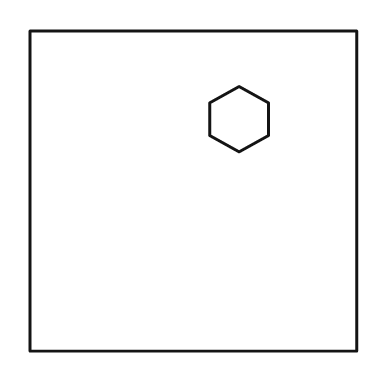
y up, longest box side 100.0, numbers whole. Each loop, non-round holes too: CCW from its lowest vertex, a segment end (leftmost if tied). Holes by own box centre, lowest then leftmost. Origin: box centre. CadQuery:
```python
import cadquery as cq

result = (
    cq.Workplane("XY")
    .moveTo(-50.0, -49.0)
    .lineTo(50.0, -49.0)
    .lineTo(50.0, 49.0)
    .lineTo(-50.0, 49.0)
    .close()
    .moveTo(14.0, 12.0)
    .lineTo(23.0, 17.0)
    .lineTo(23.0, 27.0)
    .lineTo(14.0, 32.0)
    .lineTo(5.0, 27.0)
    .lineTo(5.0, 17.0)
    .close()
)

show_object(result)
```